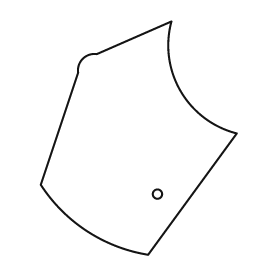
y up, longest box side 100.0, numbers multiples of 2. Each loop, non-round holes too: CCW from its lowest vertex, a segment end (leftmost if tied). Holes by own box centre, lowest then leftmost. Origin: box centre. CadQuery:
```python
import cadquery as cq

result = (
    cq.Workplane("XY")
    .moveTo(4.0, -50.0)
    .lineTo(42.0, 2.0)
    .threePointArc((18.0, 20.0), (14.0, 50.0))
    .lineTo(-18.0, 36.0)
    .threePointArc((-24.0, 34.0), (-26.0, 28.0))
    .lineTo(-42.0, -20.0)
    .threePointArc((-22.0, -40.0), (4.0, -50.0))
    .close()
    .moveTo(8.0, -24.0)
    .circle(2.0)
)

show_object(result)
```